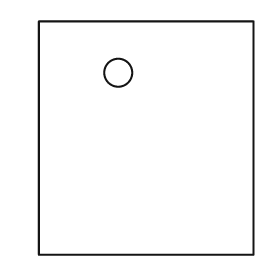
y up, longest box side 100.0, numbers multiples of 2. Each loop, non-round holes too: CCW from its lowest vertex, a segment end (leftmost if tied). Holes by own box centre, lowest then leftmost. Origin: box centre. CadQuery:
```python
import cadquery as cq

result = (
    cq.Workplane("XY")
    .moveTo(-46.0, -50.0)
    .lineTo(46.0, -50.0)
    .lineTo(46.0, 50.0)
    .lineTo(-46.0, 50.0)
    .close()
    .moveTo(-12.0, 28.0)
    .circle(6.0)
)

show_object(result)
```